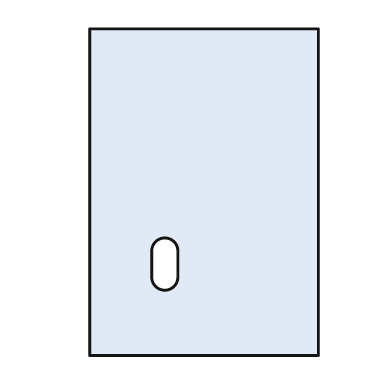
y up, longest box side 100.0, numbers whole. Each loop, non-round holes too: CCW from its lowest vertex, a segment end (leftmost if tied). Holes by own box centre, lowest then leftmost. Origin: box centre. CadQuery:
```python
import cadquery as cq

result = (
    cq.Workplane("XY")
    .moveTo(-35.0, -50.0)
    .lineTo(35.0, -50.0)
    .lineTo(35.0, 50.0)
    .lineTo(-35.0, 50.0)
    .close()
    .moveTo(-16.0, -26.0)
    .threePointArc((-12.0, -30.0), (-8.0, -26.0))
    .lineTo(-8.0, -18.0)
    .threePointArc((-12.0, -14.0), (-16.0, -18.0))
    .close()
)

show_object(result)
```